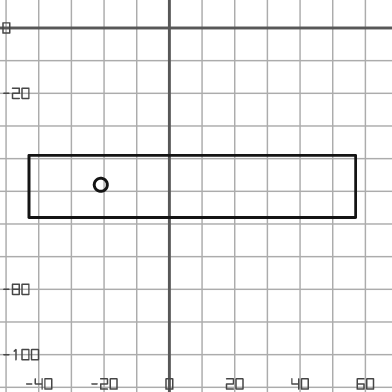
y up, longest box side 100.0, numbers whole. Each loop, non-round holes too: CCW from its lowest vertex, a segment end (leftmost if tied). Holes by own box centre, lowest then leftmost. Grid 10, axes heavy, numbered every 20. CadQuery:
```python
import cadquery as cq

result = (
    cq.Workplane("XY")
    .moveTo(-43.0, -58.0)
    .lineTo(57.0, -58.0)
    .lineTo(57.0, -39.0)
    .lineTo(-43.0, -39.0)
    .close()
    .moveTo(-21.0, -48.0)
    .circle(2.0)
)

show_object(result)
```